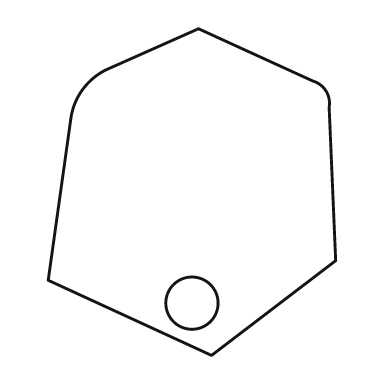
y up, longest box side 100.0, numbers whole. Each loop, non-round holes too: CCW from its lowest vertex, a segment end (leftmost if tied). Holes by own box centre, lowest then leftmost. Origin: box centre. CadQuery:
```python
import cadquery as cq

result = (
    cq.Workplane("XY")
    .moveTo(6.0, -50.0)
    .lineTo(44.0, -21.0)
    .lineTo(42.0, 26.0)
    .threePointArc((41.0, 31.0), (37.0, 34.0))
    .lineTo(2.0, 50.0)
    .lineTo(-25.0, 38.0)
    .threePointArc((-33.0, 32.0), (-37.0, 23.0))
    .lineTo(-44.0, -27.0)
    .close()
    .moveTo(0.0, -34.0)
    .circle(8.0)
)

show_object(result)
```